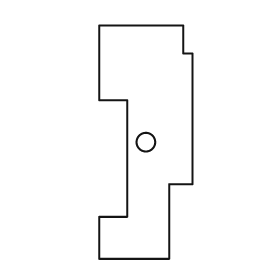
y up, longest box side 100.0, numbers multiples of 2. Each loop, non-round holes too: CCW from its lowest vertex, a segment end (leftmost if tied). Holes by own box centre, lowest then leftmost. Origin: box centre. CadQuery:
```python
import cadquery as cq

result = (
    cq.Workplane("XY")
    .moveTo(-20.0, -50.0)
    .lineTo(10.0, -50.0)
    .lineTo(10.0, -18.0)
    .lineTo(20.0, -18.0)
    .lineTo(20.0, 38.0)
    .lineTo(16.0, 38.0)
    .lineTo(16.0, 50.0)
    .lineTo(-20.0, 50.0)
    .lineTo(-20.0, 18.0)
    .lineTo(-8.0, 18.0)
    .lineTo(-8.0, -32.0)
    .lineTo(-20.0, -32.0)
    .close()
    .moveTo(0.0, 0.0)
    .circle(4.0)
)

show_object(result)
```